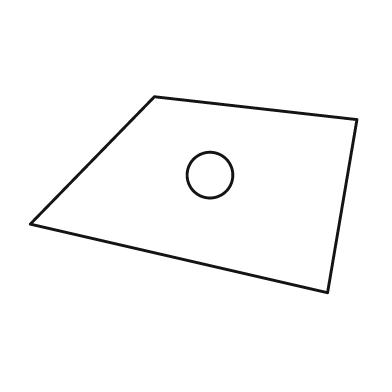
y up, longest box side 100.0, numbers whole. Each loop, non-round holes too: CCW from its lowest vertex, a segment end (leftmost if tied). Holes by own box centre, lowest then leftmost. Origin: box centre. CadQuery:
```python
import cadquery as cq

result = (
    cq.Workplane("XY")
    .moveTo(41.0, -30.0)
    .lineTo(50.0, 23.0)
    .lineTo(-12.0, 30.0)
    .lineTo(-50.0, -9.0)
    .close()
    .moveTo(5.0, 6.0)
    .circle(7.0)
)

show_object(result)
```